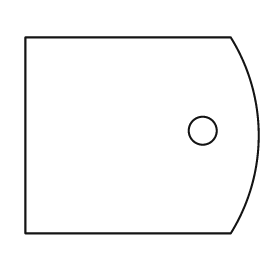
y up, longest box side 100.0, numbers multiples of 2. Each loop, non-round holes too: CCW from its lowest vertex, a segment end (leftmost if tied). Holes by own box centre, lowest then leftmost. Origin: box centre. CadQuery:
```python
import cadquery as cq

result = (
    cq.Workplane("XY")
    .moveTo(-50.0, -42.0)
    .lineTo(38.0, -42.0)
    .threePointArc((50.0, 0.0), (38.0, 42.0))
    .lineTo(-50.0, 42.0)
    .close()
    .moveTo(26.0, 2.0)
    .circle(6.0)
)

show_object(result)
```